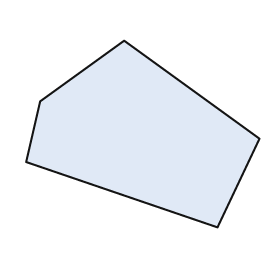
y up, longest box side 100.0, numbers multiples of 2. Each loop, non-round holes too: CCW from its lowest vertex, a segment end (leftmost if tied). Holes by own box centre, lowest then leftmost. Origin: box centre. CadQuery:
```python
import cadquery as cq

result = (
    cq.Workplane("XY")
    .moveTo(32.0, -40.0)
    .lineTo(50.0, -2.0)
    .lineTo(-8.0, 40.0)
    .lineTo(-44.0, 14.0)
    .lineTo(-50.0, -12.0)
    .close()
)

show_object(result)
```